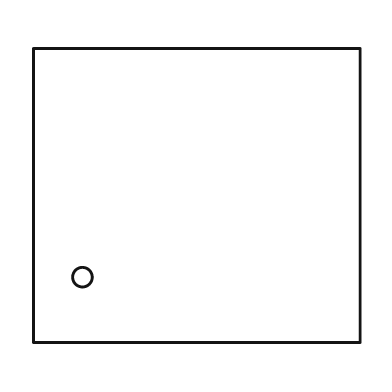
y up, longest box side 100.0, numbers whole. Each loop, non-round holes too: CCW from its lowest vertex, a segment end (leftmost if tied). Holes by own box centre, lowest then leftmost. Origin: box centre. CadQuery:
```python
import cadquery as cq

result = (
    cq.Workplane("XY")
    .moveTo(-50.0, -45.0)
    .lineTo(50.0, -45.0)
    .lineTo(50.0, 45.0)
    .lineTo(-50.0, 45.0)
    .close()
    .moveTo(-35.0, -25.0)
    .circle(3.0)
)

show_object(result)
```